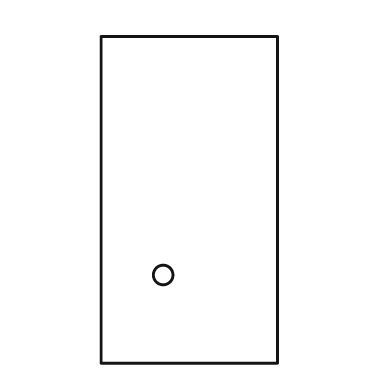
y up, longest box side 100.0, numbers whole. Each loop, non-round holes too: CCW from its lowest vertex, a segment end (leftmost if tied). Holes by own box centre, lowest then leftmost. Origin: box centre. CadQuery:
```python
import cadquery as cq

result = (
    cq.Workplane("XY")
    .moveTo(-27.0, -50.0)
    .lineTo(27.0, -50.0)
    .lineTo(27.0, 50.0)
    .lineTo(-27.0, 50.0)
    .close()
    .moveTo(-8.0, -23.0)
    .circle(3.0)
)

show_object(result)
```